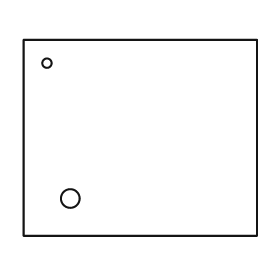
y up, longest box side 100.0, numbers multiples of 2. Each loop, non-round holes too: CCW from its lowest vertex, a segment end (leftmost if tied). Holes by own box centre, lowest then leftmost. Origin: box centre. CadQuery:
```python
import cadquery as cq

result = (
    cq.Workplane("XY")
    .moveTo(-50.0, -42.0)
    .lineTo(50.0, -42.0)
    .lineTo(50.0, 42.0)
    .lineTo(-50.0, 42.0)
    .close()
    .moveTo(-30.0, -26.0)
    .circle(4.0)
    .moveTo(-40.0, 32.0)
    .circle(2.0)
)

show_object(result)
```